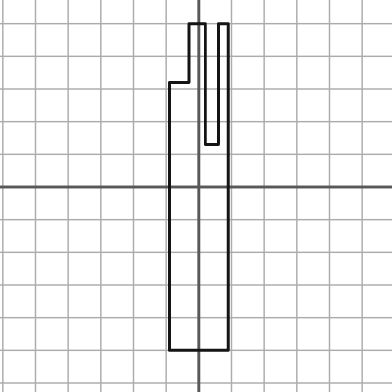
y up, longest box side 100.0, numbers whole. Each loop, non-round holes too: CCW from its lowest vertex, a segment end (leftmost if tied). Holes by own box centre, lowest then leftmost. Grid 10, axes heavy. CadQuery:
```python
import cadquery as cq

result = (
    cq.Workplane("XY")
    .moveTo(-9.0, -50.0)
    .lineTo(9.0, -50.0)
    .lineTo(9.0, 50.0)
    .lineTo(6.0, 50.0)
    .lineTo(6.0, 13.0)
    .lineTo(2.0, 13.0)
    .lineTo(2.0, 50.0)
    .lineTo(-3.0, 50.0)
    .lineTo(-3.0, 32.0)
    .lineTo(-9.0, 32.0)
    .close()
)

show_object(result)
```